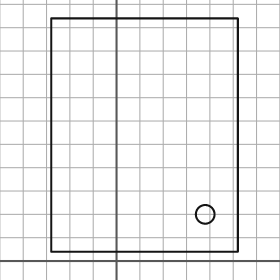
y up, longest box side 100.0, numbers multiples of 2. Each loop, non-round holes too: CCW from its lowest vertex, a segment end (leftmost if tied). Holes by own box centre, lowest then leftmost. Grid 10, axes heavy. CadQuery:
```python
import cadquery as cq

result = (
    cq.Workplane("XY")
    .moveTo(-28.0, 4.0)
    .lineTo(52.0, 4.0)
    .lineTo(52.0, 104.0)
    .lineTo(-28.0, 104.0)
    .close()
    .moveTo(38.0, 20.0)
    .circle(4.0)
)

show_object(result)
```